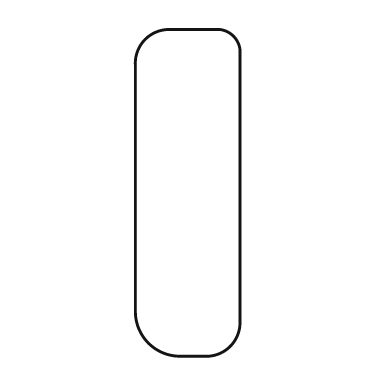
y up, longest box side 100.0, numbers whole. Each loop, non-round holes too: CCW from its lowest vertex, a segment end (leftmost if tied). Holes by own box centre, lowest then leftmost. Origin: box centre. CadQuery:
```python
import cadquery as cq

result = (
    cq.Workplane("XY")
    .moveTo(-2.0, -50.0)
    .lineTo(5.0, -50.0)
    .threePointArc((13.0, -47.0), (16.0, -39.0))
    .lineTo(16.0, 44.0)
    .threePointArc((14.0, 48.0), (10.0, 50.0))
    .lineTo(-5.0, 50.0)
    .threePointArc((-13.0, 47.0), (-16.0, 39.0))
    .lineTo(-16.0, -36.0)
    .threePointArc((-12.0, -46.0), (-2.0, -50.0))
    .close()
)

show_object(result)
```